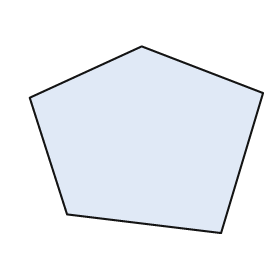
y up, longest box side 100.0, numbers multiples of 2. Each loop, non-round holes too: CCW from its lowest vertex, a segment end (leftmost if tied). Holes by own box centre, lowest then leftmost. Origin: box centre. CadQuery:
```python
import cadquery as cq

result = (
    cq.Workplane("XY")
    .moveTo(32.0, -40.0)
    .lineTo(50.0, 20.0)
    .lineTo(-2.0, 40.0)
    .lineTo(-50.0, 18.0)
    .lineTo(-34.0, -32.0)
    .close()
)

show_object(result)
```